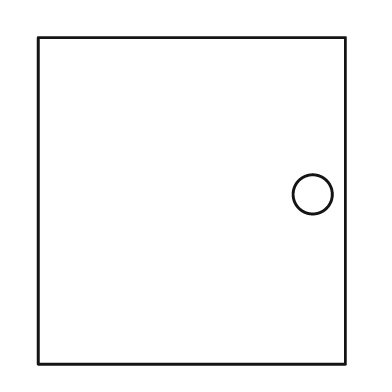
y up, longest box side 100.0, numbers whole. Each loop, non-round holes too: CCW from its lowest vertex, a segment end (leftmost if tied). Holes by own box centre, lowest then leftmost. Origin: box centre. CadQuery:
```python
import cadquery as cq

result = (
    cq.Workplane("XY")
    .moveTo(-47.0, -50.0)
    .lineTo(47.0, -50.0)
    .lineTo(47.0, 50.0)
    .lineTo(-47.0, 50.0)
    .close()
    .moveTo(37.0, 2.0)
    .circle(6.0)
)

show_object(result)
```